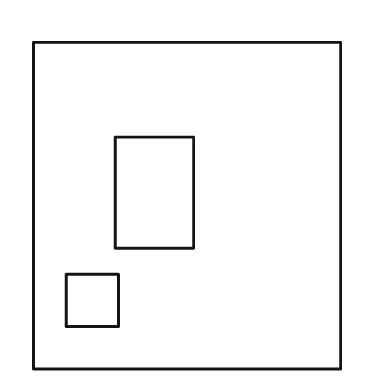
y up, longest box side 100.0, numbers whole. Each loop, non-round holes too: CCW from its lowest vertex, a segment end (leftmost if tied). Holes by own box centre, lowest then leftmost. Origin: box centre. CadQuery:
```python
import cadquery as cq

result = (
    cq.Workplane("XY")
    .moveTo(-47.0, -50.0)
    .lineTo(47.0, -50.0)
    .lineTo(47.0, 50.0)
    .lineTo(-47.0, 50.0)
    .close()
    .moveTo(-37.0, -37.0)
    .lineTo(-21.0, -37.0)
    .lineTo(-21.0, -21.0)
    .lineTo(-37.0, -21.0)
    .close()
    .moveTo(-22.0, -13.0)
    .lineTo(2.0, -13.0)
    .lineTo(2.0, 21.0)
    .lineTo(-22.0, 21.0)
    .close()
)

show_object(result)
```